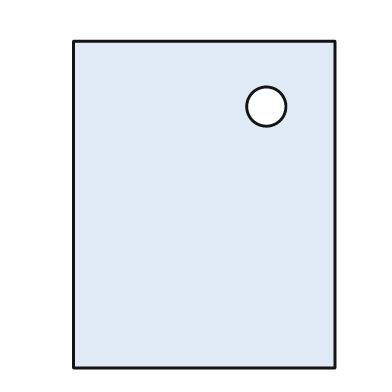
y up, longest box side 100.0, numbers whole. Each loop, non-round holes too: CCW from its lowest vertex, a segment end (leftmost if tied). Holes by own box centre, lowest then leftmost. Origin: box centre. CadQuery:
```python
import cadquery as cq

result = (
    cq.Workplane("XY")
    .moveTo(-40.0, -50.0)
    .lineTo(40.0, -50.0)
    .lineTo(40.0, 50.0)
    .lineTo(-40.0, 50.0)
    .close()
    .moveTo(19.0, 30.0)
    .circle(6.0)
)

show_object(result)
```